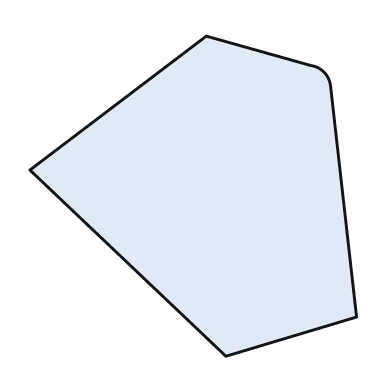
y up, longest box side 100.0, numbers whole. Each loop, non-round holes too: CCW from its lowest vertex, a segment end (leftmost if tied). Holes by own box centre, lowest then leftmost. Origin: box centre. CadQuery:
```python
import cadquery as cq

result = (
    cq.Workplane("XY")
    .moveTo(10.0, -49.0)
    .lineTo(50.0, -37.0)
    .lineTo(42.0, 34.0)
    .threePointArc((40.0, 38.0), (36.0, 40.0))
    .lineTo(4.0, 49.0)
    .lineTo(-50.0, 8.0)
    .close()
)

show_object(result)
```